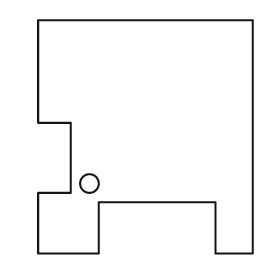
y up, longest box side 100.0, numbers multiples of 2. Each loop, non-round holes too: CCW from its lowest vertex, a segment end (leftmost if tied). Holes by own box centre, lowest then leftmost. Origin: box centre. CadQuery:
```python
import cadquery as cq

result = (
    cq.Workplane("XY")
    .moveTo(-46.0, -50.0)
    .lineTo(-20.0, -50.0)
    .lineTo(-20.0, -28.0)
    .lineTo(30.0, -28.0)
    .lineTo(30.0, -50.0)
    .lineTo(46.0, -50.0)
    .lineTo(46.0, 50.0)
    .lineTo(-46.0, 50.0)
    .lineTo(-46.0, 6.0)
    .lineTo(-32.0, 6.0)
    .lineTo(-32.0, -24.0)
    .lineTo(-46.0, -24.0)
    .close()
    .moveTo(-24.0, -20.0)
    .circle(4.0)
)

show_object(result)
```